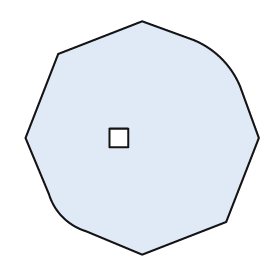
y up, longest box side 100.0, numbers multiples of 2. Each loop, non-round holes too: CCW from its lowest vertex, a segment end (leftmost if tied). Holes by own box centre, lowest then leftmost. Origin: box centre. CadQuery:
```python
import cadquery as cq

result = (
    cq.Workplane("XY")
    .moveTo(0.0, -50.0)
    .lineTo(36.0, -36.0)
    .lineTo(50.0, 0.0)
    .lineTo(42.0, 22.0)
    .threePointArc((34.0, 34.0), (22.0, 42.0))
    .lineTo(0.0, 50.0)
    .lineTo(-36.0, 36.0)
    .lineTo(-50.0, 0.0)
    .lineTo(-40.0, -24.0)
    .threePointArc((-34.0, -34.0), (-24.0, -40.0))
    .close()
    .moveTo(-14.0, -4.0)
    .lineTo(-6.0, -4.0)
    .lineTo(-6.0, 4.0)
    .lineTo(-14.0, 4.0)
    .close()
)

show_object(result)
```